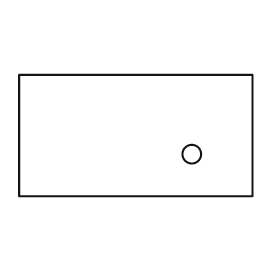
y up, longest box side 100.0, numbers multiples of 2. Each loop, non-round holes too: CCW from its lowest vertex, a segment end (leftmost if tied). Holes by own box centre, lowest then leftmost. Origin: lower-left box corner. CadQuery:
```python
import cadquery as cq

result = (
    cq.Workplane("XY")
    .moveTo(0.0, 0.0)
    .lineTo(100.0, 0.0)
    .lineTo(100.0, 52.0)
    .lineTo(0.0, 52.0)
    .close()
    .moveTo(74.0, 18.0)
    .circle(4.0)
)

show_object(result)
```